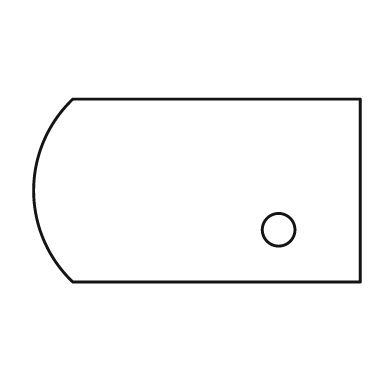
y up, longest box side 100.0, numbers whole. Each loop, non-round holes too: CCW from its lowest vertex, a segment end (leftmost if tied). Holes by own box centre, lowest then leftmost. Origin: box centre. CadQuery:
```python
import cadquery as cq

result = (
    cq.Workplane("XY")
    .moveTo(-38.0, -28.0)
    .lineTo(50.0, -28.0)
    .lineTo(50.0, 28.0)
    .lineTo(-38.0, 28.0)
    .threePointArc((-50.0, 0.0), (-38.0, -28.0))
    .close()
    .moveTo(25.0, -12.0)
    .circle(5.0)
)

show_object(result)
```